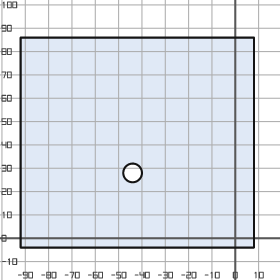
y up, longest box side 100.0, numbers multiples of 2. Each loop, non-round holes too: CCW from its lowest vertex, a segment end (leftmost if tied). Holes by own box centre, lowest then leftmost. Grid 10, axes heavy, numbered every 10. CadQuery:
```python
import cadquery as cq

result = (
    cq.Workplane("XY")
    .moveTo(-92.0, -4.0)
    .lineTo(8.0, -4.0)
    .lineTo(8.0, 86.0)
    .lineTo(-92.0, 86.0)
    .close()
    .moveTo(-44.0, 28.0)
    .circle(4.0)
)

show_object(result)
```